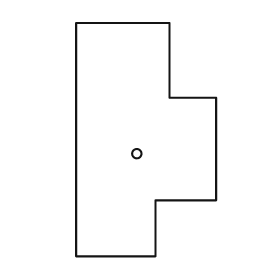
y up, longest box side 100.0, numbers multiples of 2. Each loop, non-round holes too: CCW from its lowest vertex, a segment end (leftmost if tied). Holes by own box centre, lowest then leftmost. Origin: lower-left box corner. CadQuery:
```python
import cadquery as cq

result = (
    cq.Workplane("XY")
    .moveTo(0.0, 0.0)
    .lineTo(34.0, 0.0)
    .lineTo(34.0, 24.0)
    .lineTo(60.0, 24.0)
    .lineTo(60.0, 68.0)
    .lineTo(40.0, 68.0)
    .lineTo(40.0, 100.0)
    .lineTo(0.0, 100.0)
    .close()
    .moveTo(26.0, 44.0)
    .circle(2.0)
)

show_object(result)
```